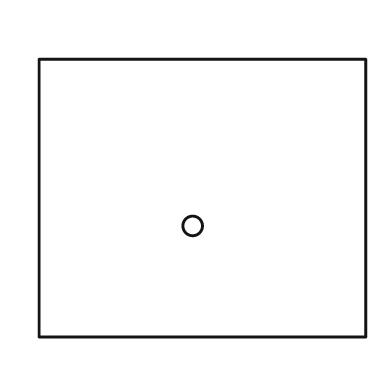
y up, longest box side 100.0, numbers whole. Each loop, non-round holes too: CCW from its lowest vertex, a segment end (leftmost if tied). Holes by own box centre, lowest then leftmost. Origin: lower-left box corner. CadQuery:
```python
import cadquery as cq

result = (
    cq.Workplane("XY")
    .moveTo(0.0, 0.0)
    .lineTo(100.0, 0.0)
    .lineTo(100.0, 85.0)
    .lineTo(0.0, 85.0)
    .close()
    .moveTo(47.0, 34.0)
    .circle(3.0)
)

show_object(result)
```